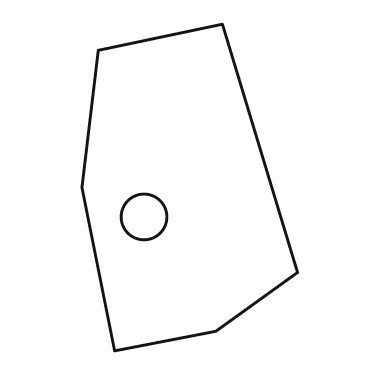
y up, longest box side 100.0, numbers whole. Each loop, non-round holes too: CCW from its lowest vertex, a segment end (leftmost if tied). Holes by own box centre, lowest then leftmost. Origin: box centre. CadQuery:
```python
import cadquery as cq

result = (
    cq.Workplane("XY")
    .moveTo(-23.0, -50.0)
    .lineTo(8.0, -44.0)
    .lineTo(33.0, -26.0)
    .lineTo(10.0, 50.0)
    .lineTo(-28.0, 42.0)
    .lineTo(-33.0, 0.0)
    .close()
    .moveTo(-14.0, -9.0)
    .circle(7.0)
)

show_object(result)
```